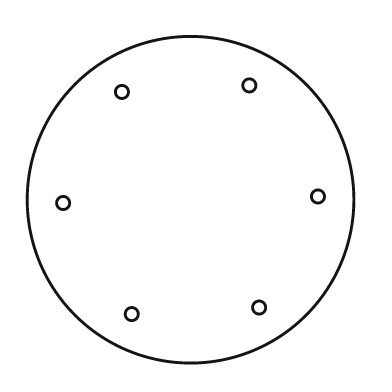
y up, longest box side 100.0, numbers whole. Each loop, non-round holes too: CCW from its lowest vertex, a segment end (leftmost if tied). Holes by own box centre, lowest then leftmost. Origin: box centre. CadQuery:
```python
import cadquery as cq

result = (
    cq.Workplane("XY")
    .moveTo(0.0, 0.0)
    .circle(50.0)
    .moveTo(-18.0, -35.0)
    .circle(2.0)
    .moveTo(21.0, -33.0)
    .circle(2.0)
    .moveTo(-39.0, -1.0)
    .circle(2.0)
    .moveTo(39.0, 1.0)
    .circle(2.0)
    .moveTo(-21.0, 33.0)
    .circle(2.0)
    .moveTo(18.0, 35.0)
    .circle(2.0)
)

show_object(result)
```